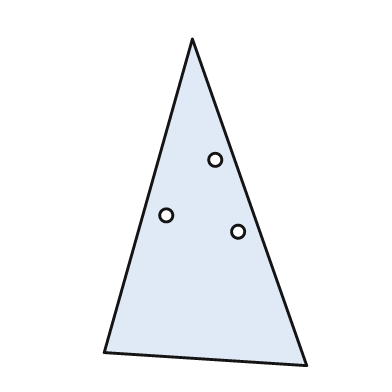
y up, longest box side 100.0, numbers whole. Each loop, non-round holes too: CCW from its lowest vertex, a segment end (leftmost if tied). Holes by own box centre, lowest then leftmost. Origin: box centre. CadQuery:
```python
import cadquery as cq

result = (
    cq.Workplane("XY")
    .moveTo(31.0, -50.0)
    .lineTo(-4.0, 50.0)
    .lineTo(-31.0, -46.0)
    .close()
    .moveTo(10.0, -9.0)
    .circle(2.0)
    .moveTo(-12.0, -4.0)
    .circle(2.0)
    .moveTo(3.0, 13.0)
    .circle(2.0)
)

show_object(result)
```